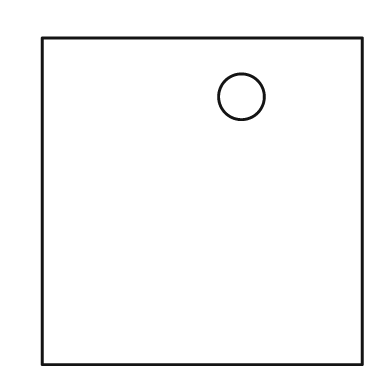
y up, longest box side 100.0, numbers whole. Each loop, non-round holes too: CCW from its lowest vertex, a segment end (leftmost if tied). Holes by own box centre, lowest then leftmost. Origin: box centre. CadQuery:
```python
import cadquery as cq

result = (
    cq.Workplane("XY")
    .moveTo(-49.0, -50.0)
    .lineTo(49.0, -50.0)
    .lineTo(49.0, 50.0)
    .lineTo(-49.0, 50.0)
    .close()
    .moveTo(12.0, 32.0)
    .circle(7.0)
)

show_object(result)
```